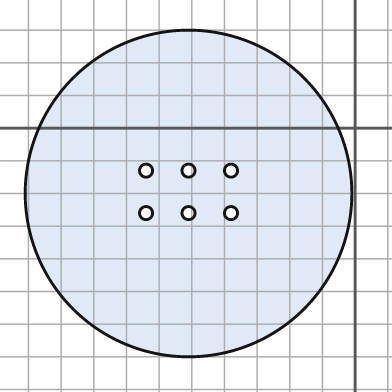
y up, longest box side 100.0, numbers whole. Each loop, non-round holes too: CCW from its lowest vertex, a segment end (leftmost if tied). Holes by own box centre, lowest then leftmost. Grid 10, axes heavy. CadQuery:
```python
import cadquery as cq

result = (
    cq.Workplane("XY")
    .moveTo(-51.0, -20.0)
    .circle(50.0)
    .moveTo(-64.0, -26.0)
    .circle(2.0)
    .moveTo(-51.0, -26.0)
    .circle(2.0)
    .moveTo(-38.0, -26.0)
    .circle(2.0)
    .moveTo(-64.0, -13.0)
    .circle(2.0)
    .moveTo(-51.0, -13.0)
    .circle(2.0)
    .moveTo(-38.0, -13.0)
    .circle(2.0)
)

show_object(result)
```